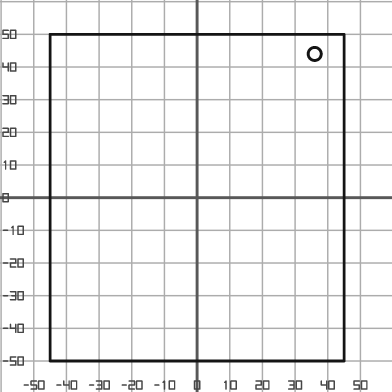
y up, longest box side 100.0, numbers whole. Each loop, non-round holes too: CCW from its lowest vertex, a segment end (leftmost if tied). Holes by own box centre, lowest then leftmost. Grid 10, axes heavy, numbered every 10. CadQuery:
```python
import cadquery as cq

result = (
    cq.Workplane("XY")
    .moveTo(-45.0, -50.0)
    .lineTo(45.0, -50.0)
    .lineTo(45.0, 50.0)
    .lineTo(-45.0, 50.0)
    .close()
    .moveTo(36.0, 44.0)
    .circle(2.0)
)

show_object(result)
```